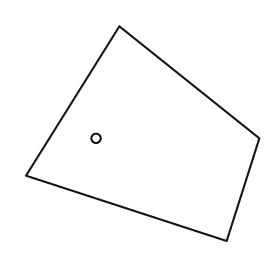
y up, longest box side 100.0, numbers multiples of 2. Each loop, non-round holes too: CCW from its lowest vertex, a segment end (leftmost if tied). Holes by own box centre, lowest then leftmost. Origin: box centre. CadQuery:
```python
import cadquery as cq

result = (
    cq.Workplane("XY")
    .moveTo(36.0, -46.0)
    .lineTo(50.0, -2.0)
    .lineTo(-10.0, 46.0)
    .lineTo(-50.0, -18.0)
    .close()
    .moveTo(-20.0, -2.0)
    .circle(2.0)
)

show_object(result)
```